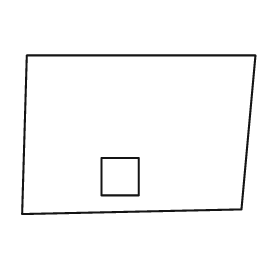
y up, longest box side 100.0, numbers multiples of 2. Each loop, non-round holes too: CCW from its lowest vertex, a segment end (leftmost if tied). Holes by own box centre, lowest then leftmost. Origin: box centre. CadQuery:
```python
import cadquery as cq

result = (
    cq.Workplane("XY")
    .moveTo(-50.0, -34.0)
    .lineTo(44.0, -32.0)
    .lineTo(50.0, 34.0)
    .lineTo(-48.0, 34.0)
    .close()
    .moveTo(-16.0, -26.0)
    .lineTo(0.0, -26.0)
    .lineTo(0.0, -10.0)
    .lineTo(-16.0, -10.0)
    .close()
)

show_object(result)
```